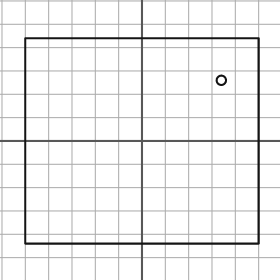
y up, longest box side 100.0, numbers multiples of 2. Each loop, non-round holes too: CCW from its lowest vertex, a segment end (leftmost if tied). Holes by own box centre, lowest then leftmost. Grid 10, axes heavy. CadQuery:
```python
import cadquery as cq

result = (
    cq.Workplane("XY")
    .moveTo(-50.0, -44.0)
    .lineTo(50.0, -44.0)
    .lineTo(50.0, 44.0)
    .lineTo(-50.0, 44.0)
    .close()
    .moveTo(34.0, 26.0)
    .circle(2.0)
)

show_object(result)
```